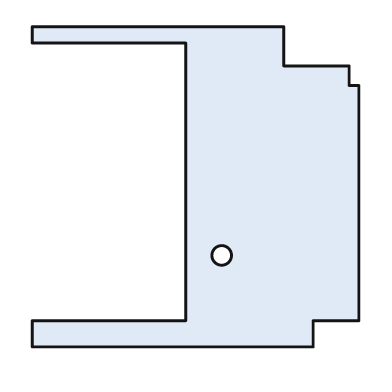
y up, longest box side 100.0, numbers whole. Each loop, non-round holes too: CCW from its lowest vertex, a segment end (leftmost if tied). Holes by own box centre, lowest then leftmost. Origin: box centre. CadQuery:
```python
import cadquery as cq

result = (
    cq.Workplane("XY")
    .moveTo(-50.0, -49.0)
    .lineTo(36.0, -49.0)
    .lineTo(36.0, -41.0)
    .lineTo(50.0, -41.0)
    .lineTo(50.0, 31.0)
    .lineTo(47.0, 31.0)
    .lineTo(47.0, 37.0)
    .lineTo(27.0, 37.0)
    .lineTo(27.0, 49.0)
    .lineTo(-50.0, 49.0)
    .lineTo(-50.0, 44.0)
    .lineTo(-3.0, 44.0)
    .lineTo(-3.0, -41.0)
    .lineTo(-50.0, -41.0)
    .close()
    .moveTo(8.0, -21.0)
    .circle(3.0)
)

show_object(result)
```